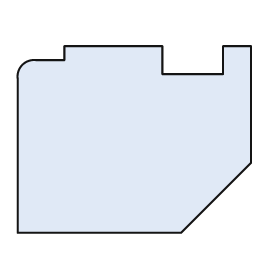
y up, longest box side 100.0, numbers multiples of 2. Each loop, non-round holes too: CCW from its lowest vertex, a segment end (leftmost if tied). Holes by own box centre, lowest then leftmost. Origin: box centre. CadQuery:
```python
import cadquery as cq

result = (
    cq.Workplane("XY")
    .moveTo(-50.0, -40.0)
    .lineTo(20.0, -40.0)
    .lineTo(50.0, -10.0)
    .lineTo(50.0, 40.0)
    .lineTo(38.0, 40.0)
    .lineTo(38.0, 28.0)
    .lineTo(12.0, 28.0)
    .lineTo(12.0, 40.0)
    .lineTo(-30.0, 40.0)
    .lineTo(-30.0, 34.0)
    .lineTo(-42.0, 34.0)
    .threePointArc((-48.0, 32.0), (-50.0, 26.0))
    .close()
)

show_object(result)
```